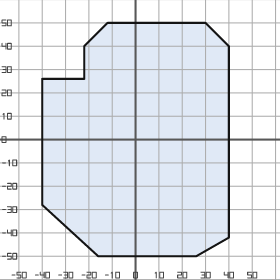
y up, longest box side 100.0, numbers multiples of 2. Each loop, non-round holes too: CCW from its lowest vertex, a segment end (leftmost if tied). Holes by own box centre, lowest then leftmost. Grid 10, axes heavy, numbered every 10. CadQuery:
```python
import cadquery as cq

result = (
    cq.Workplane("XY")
    .moveTo(-16.0, -50.0)
    .lineTo(26.0, -50.0)
    .lineTo(40.0, -42.0)
    .lineTo(40.0, 40.0)
    .lineTo(30.0, 50.0)
    .lineTo(-12.0, 50.0)
    .lineTo(-22.0, 40.0)
    .lineTo(-22.0, 26.0)
    .lineTo(-40.0, 26.0)
    .lineTo(-40.0, -28.0)
    .close()
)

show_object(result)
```